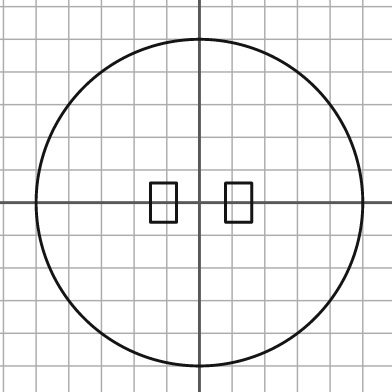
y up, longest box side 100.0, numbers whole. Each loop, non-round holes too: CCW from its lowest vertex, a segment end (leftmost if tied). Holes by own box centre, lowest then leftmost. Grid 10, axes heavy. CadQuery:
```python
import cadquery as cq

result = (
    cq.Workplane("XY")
    .moveTo(0.0, 0.0)
    .circle(50.0)
    .moveTo(-15.0, -6.0)
    .lineTo(-7.0, -6.0)
    .lineTo(-7.0, 6.0)
    .lineTo(-15.0, 6.0)
    .close()
    .moveTo(8.0, -6.0)
    .lineTo(16.0, -6.0)
    .lineTo(16.0, 6.0)
    .lineTo(8.0, 6.0)
    .close()
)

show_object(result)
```